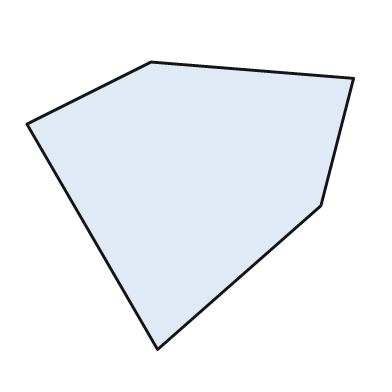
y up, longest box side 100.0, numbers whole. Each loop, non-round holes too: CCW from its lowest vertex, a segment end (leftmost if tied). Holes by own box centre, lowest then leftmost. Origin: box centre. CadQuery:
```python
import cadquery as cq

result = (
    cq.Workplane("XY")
    .moveTo(-10.0, -44.0)
    .lineTo(40.0, 0.0)
    .lineTo(50.0, 39.0)
    .lineTo(-12.0, 44.0)
    .lineTo(-50.0, 25.0)
    .close()
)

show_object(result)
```